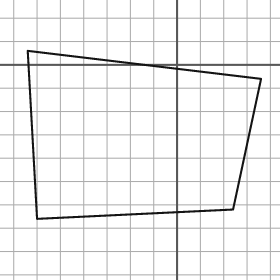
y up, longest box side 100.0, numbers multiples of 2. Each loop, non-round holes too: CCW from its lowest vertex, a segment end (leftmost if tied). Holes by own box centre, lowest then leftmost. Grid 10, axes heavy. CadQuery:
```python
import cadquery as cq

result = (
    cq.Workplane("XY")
    .moveTo(-60.0, -66.0)
    .lineTo(24.0, -62.0)
    .lineTo(36.0, -6.0)
    .lineTo(-64.0, 6.0)
    .close()
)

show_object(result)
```